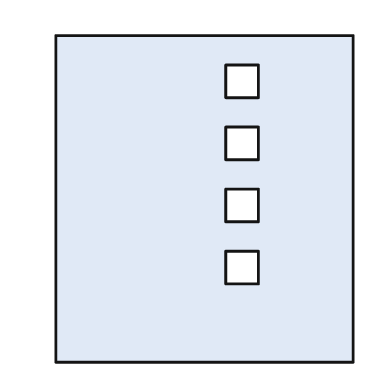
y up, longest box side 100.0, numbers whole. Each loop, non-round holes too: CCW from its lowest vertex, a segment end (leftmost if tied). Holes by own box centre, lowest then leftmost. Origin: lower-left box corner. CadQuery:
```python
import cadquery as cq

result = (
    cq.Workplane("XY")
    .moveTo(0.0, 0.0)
    .lineTo(91.0, 0.0)
    .lineTo(91.0, 100.0)
    .lineTo(0.0, 100.0)
    .close()
    .moveTo(52.0, 24.0)
    .lineTo(62.0, 24.0)
    .lineTo(62.0, 34.0)
    .lineTo(52.0, 34.0)
    .close()
    .moveTo(52.0, 43.0)
    .lineTo(62.0, 43.0)
    .lineTo(62.0, 53.0)
    .lineTo(52.0, 53.0)
    .close()
    .moveTo(52.0, 62.0)
    .lineTo(62.0, 62.0)
    .lineTo(62.0, 72.0)
    .lineTo(52.0, 72.0)
    .close()
    .moveTo(52.0, 81.0)
    .lineTo(62.0, 81.0)
    .lineTo(62.0, 91.0)
    .lineTo(52.0, 91.0)
    .close()
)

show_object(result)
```